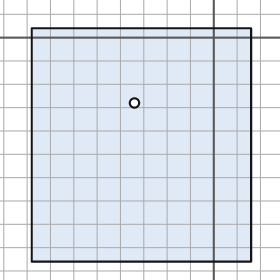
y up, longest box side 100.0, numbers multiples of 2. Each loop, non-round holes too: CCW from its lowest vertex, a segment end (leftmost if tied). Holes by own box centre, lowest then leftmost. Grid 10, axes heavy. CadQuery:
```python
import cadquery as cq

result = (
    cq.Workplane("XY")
    .moveTo(-78.0, -96.0)
    .lineTo(16.0, -96.0)
    .lineTo(16.0, 4.0)
    .lineTo(-78.0, 4.0)
    .close()
    .moveTo(-34.0, -28.0)
    .circle(2.0)
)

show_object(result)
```